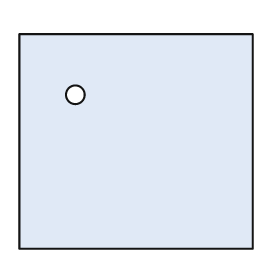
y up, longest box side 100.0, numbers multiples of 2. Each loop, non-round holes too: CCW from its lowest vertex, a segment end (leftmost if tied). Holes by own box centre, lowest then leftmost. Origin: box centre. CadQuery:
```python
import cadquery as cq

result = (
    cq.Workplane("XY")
    .moveTo(-50.0, -46.0)
    .lineTo(50.0, -46.0)
    .lineTo(50.0, 46.0)
    .lineTo(-50.0, 46.0)
    .close()
    .moveTo(-26.0, 20.0)
    .circle(4.0)
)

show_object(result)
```